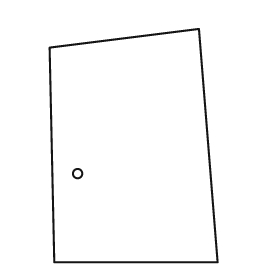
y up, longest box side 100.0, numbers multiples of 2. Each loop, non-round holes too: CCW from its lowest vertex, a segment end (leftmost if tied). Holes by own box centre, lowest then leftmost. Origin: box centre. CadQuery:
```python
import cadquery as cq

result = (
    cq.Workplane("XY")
    .moveTo(-34.0, -50.0)
    .lineTo(36.0, -50.0)
    .lineTo(28.0, 50.0)
    .lineTo(-36.0, 42.0)
    .close()
    .moveTo(-24.0, -12.0)
    .circle(2.0)
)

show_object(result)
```